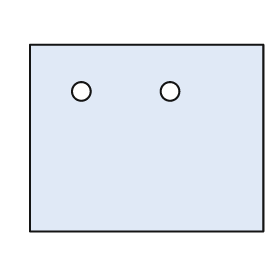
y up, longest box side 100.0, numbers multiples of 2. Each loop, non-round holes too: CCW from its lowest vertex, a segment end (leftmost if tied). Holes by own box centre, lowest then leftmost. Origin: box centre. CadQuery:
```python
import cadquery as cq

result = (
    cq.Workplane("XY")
    .moveTo(-50.0, -40.0)
    .lineTo(50.0, -40.0)
    .lineTo(50.0, 40.0)
    .lineTo(-50.0, 40.0)
    .close()
    .moveTo(-28.0, 20.0)
    .circle(4.0)
    .moveTo(10.0, 20.0)
    .circle(4.0)
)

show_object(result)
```